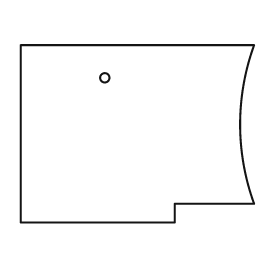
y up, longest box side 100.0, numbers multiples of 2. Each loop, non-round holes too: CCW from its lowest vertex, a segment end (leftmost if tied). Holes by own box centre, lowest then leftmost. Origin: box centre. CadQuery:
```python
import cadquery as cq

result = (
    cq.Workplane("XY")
    .moveTo(-50.0, -38.0)
    .lineTo(16.0, -38.0)
    .lineTo(16.0, -30.0)
    .lineTo(50.0, -30.0)
    .threePointArc((44.0, 4.0), (50.0, 38.0))
    .lineTo(-50.0, 38.0)
    .close()
    .moveTo(-14.0, 24.0)
    .circle(2.0)
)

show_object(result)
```